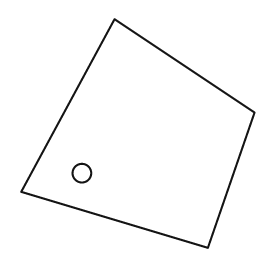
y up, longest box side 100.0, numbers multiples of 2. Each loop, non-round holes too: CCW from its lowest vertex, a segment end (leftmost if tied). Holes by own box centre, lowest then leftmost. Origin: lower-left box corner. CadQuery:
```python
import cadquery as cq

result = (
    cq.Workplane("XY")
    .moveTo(80.0, 0.0)
    .lineTo(100.0, 58.0)
    .lineTo(40.0, 98.0)
    .lineTo(0.0, 24.0)
    .close()
    .moveTo(26.0, 32.0)
    .circle(4.0)
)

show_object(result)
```